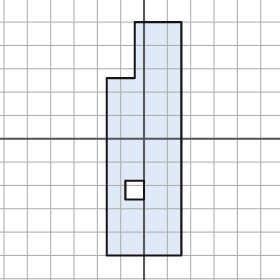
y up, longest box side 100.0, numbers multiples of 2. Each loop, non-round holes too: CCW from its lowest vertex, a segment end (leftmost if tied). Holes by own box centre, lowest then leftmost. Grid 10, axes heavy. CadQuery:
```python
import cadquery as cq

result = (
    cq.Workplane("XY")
    .moveTo(-16.0, -50.0)
    .lineTo(16.0, -50.0)
    .lineTo(16.0, 50.0)
    .lineTo(-4.0, 50.0)
    .lineTo(-4.0, 26.0)
    .lineTo(-16.0, 26.0)
    .close()
    .moveTo(-8.0, -26.0)
    .lineTo(0.0, -26.0)
    .lineTo(0.0, -18.0)
    .lineTo(-8.0, -18.0)
    .close()
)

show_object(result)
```